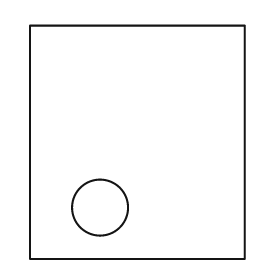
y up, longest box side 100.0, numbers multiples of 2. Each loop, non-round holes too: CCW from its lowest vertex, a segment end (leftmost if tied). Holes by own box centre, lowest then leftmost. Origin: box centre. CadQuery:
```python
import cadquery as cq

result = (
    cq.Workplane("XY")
    .moveTo(-46.0, -50.0)
    .lineTo(46.0, -50.0)
    .lineTo(46.0, 50.0)
    .lineTo(-46.0, 50.0)
    .close()
    .moveTo(-16.0, -28.0)
    .circle(12.0)
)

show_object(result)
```